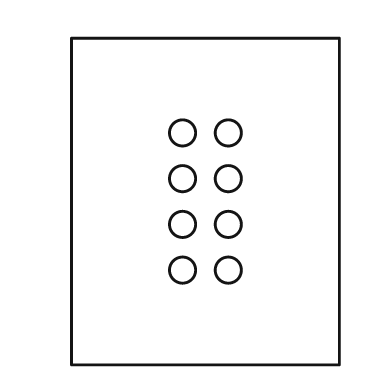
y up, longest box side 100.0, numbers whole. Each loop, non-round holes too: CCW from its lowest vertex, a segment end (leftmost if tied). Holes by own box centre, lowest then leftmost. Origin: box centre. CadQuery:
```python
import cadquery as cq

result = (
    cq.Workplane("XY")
    .moveTo(-41.0, -50.0)
    .lineTo(41.0, -50.0)
    .lineTo(41.0, 50.0)
    .lineTo(-41.0, 50.0)
    .close()
    .moveTo(-7.0, -21.0)
    .circle(4.0)
    .moveTo(7.0, -21.0)
    .circle(4.0)
    .moveTo(-7.0, -7.0)
    .circle(4.0)
    .moveTo(7.0, -7.0)
    .circle(4.0)
    .moveTo(-7.0, 7.0)
    .circle(4.0)
    .moveTo(7.0, 7.0)
    .circle(4.0)
    .moveTo(-7.0, 21.0)
    .circle(4.0)
    .moveTo(7.0, 21.0)
    .circle(4.0)
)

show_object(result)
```